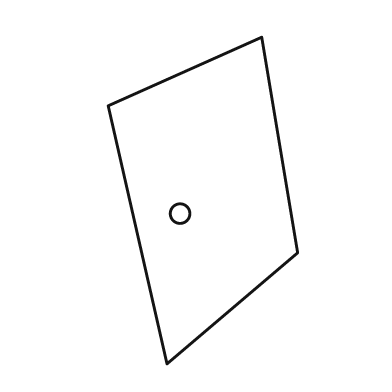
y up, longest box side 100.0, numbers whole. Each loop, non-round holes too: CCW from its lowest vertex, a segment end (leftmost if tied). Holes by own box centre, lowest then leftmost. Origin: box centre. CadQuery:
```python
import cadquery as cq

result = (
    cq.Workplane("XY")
    .moveTo(-11.0, -50.0)
    .lineTo(29.0, -16.0)
    .lineTo(18.0, 50.0)
    .lineTo(-29.0, 29.0)
    .close()
    .moveTo(-7.0, -4.0)
    .circle(3.0)
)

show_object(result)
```